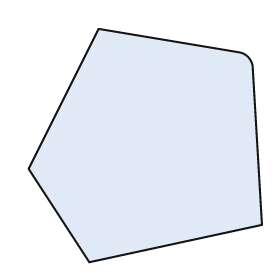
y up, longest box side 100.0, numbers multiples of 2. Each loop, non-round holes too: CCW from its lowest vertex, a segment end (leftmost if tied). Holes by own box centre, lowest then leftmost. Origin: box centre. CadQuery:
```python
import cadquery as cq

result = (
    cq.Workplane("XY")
    .moveTo(-24.0, -50.0)
    .lineTo(50.0, -34.0)
    .lineTo(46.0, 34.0)
    .threePointArc((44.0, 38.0), (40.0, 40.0))
    .lineTo(-20.0, 50.0)
    .lineTo(-50.0, -10.0)
    .close()
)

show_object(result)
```